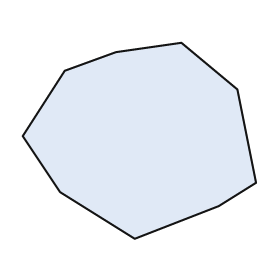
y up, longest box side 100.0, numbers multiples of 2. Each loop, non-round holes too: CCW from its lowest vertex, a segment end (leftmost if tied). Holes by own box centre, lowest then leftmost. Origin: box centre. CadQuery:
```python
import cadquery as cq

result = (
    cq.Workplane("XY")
    .moveTo(-2.0, -42.0)
    .lineTo(34.0, -28.0)
    .lineTo(50.0, -18.0)
    .lineTo(42.0, 22.0)
    .lineTo(18.0, 42.0)
    .lineTo(-10.0, 38.0)
    .lineTo(-32.0, 30.0)
    .lineTo(-50.0, 2.0)
    .lineTo(-34.0, -22.0)
    .close()
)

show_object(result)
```